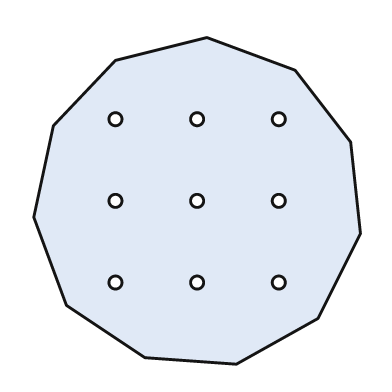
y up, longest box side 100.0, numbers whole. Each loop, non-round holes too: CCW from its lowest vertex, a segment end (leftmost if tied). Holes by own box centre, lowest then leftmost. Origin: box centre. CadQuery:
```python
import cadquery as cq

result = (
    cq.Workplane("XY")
    .moveTo(12.0, -50.0)
    .lineTo(37.0, -36.0)
    .lineTo(50.0, -10.0)
    .lineTo(47.0, 18.0)
    .lineTo(30.0, 40.0)
    .lineTo(3.0, 50.0)
    .lineTo(-25.0, 43.0)
    .lineTo(-44.0, 23.0)
    .lineTo(-50.0, -5.0)
    .lineTo(-40.0, -32.0)
    .lineTo(-16.0, -48.0)
    .close()
    .moveTo(-25.0, -25.0)
    .circle(2.0)
    .moveTo(0.0, -25.0)
    .circle(2.0)
    .moveTo(25.0, -25.0)
    .circle(2.0)
    .moveTo(-25.0, 0.0)
    .circle(2.0)
    .moveTo(0.0, 0.0)
    .circle(2.0)
    .moveTo(25.0, 0.0)
    .circle(2.0)
    .moveTo(-25.0, 25.0)
    .circle(2.0)
    .moveTo(0.0, 25.0)
    .circle(2.0)
    .moveTo(25.0, 25.0)
    .circle(2.0)
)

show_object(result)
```